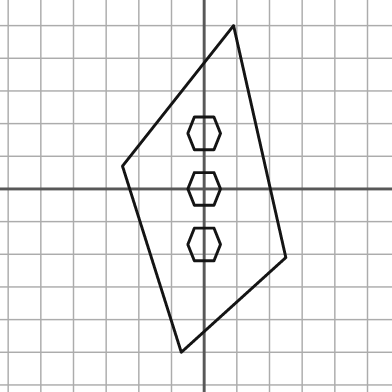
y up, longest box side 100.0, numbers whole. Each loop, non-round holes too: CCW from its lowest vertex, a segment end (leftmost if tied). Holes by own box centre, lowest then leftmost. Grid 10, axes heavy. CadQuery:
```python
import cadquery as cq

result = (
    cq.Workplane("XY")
    .moveTo(-7.0, -50.0)
    .lineTo(25.0, -21.0)
    .lineTo(9.0, 50.0)
    .lineTo(-25.0, 7.0)
    .close()
    .moveTo(-3.0, -22.0)
    .lineTo(3.0, -22.0)
    .lineTo(5.0, -17.0)
    .lineTo(3.0, -12.0)
    .lineTo(-3.0, -12.0)
    .lineTo(-5.0, -17.0)
    .close()
    .moveTo(-3.0, -5.0)
    .lineTo(3.0, -5.0)
    .lineTo(5.0, 0.0)
    .lineTo(3.0, 5.0)
    .lineTo(-3.0, 5.0)
    .lineTo(-5.0, 0.0)
    .close()
    .moveTo(-3.0, 12.0)
    .lineTo(3.0, 12.0)
    .lineTo(5.0, 17.0)
    .lineTo(3.0, 22.0)
    .lineTo(-3.0, 22.0)
    .lineTo(-5.0, 17.0)
    .close()
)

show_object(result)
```